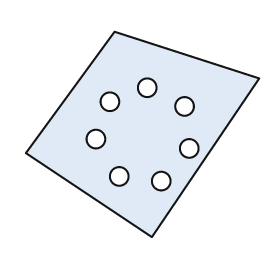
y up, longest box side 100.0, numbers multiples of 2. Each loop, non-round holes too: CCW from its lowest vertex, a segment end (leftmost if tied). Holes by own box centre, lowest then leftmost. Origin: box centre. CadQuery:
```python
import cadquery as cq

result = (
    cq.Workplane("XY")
    .moveTo(4.0, -44.0)
    .lineTo(50.0, 24.0)
    .lineTo(-12.0, 44.0)
    .lineTo(-50.0, -8.0)
    .close()
    .moveTo(8.0, -20.0)
    .circle(4.0)
    .moveTo(-10.0, -18.0)
    .circle(4.0)
    .moveTo(20.0, -6.0)
    .circle(4.0)
    .moveTo(-20.0, -2.0)
    .circle(4.0)
    .moveTo(18.0, 12.0)
    .circle(4.0)
    .moveTo(-14.0, 14.0)
    .circle(4.0)
    .moveTo(2.0, 20.0)
    .circle(4.0)
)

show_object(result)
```